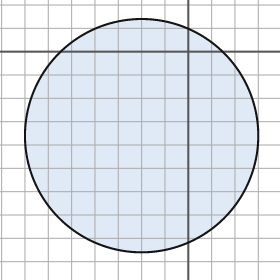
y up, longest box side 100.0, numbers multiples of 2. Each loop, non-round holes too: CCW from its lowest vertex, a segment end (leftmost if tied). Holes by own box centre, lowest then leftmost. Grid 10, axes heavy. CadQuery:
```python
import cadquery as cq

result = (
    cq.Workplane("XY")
    .moveTo(-20.0, -36.0)
    .circle(50.0)
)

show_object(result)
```